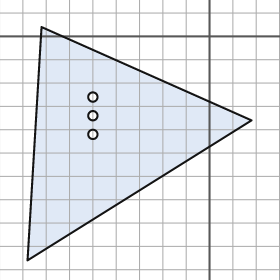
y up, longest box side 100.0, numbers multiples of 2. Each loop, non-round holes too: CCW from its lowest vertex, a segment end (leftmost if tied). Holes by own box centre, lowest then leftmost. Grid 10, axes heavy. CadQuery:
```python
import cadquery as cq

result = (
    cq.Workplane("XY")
    .moveTo(-78.0, -96.0)
    .lineTo(18.0, -36.0)
    .lineTo(-72.0, 4.0)
    .close()
    .moveTo(-50.0, -42.0)
    .circle(2.0)
    .moveTo(-50.0, -34.0)
    .circle(2.0)
    .moveTo(-50.0, -26.0)
    .circle(2.0)
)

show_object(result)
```